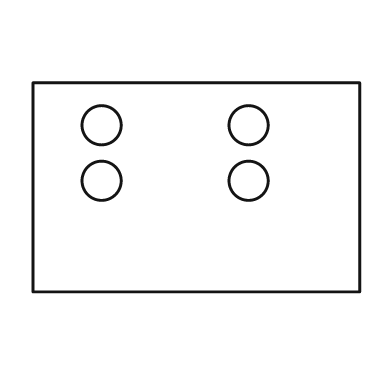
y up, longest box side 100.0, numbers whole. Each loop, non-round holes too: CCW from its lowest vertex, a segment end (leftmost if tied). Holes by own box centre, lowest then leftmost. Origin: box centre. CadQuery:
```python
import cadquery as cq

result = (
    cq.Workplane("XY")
    .moveTo(-50.0, -32.0)
    .lineTo(50.0, -32.0)
    .lineTo(50.0, 32.0)
    .lineTo(-50.0, 32.0)
    .close()
    .moveTo(-29.0, 2.0)
    .circle(6.0)
    .moveTo(16.0, 2.0)
    .circle(6.0)
    .moveTo(-29.0, 19.0)
    .circle(6.0)
    .moveTo(16.0, 19.0)
    .circle(6.0)
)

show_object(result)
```